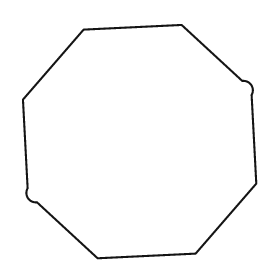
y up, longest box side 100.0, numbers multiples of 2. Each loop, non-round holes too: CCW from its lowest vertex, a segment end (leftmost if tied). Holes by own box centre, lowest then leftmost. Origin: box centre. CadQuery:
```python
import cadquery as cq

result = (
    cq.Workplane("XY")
    .moveTo(-18.0, -50.0)
    .lineTo(24.0, -48.0)
    .lineTo(50.0, -18.0)
    .lineTo(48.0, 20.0)
    .threePointArc((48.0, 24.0), (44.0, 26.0))
    .lineTo(18.0, 50.0)
    .lineTo(-24.0, 48.0)
    .lineTo(-50.0, 18.0)
    .lineTo(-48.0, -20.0)
    .threePointArc((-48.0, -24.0), (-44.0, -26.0))
    .close()
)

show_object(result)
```